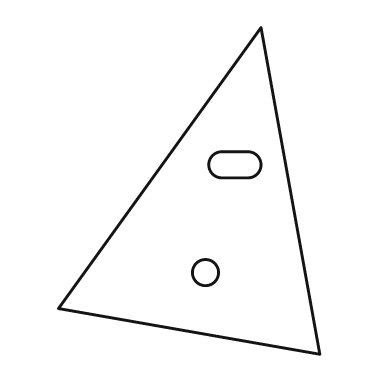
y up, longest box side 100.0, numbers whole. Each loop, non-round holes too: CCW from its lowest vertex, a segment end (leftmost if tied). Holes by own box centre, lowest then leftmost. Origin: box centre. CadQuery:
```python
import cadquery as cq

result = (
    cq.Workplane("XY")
    .moveTo(40.0, -50.0)
    .lineTo(22.0, 50.0)
    .lineTo(-40.0, -36.0)
    .close()
    .moveTo(5.0, -25.0)
    .circle(4.0)
    .moveTo(10.0, 4.0)
    .lineTo(18.0, 4.0)
    .threePointArc((22.0, 8.0), (18.0, 12.0))
    .lineTo(10.0, 12.0)
    .threePointArc((6.0, 8.0), (10.0, 4.0))
    .close()
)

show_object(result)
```